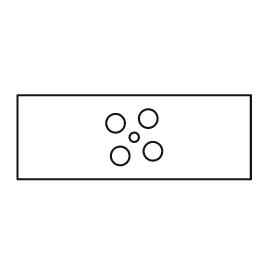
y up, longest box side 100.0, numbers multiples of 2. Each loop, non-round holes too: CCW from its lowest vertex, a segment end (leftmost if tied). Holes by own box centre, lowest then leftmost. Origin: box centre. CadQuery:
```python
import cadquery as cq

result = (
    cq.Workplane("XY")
    .moveTo(-50.0, -18.0)
    .lineTo(50.0, -18.0)
    .lineTo(50.0, 18.0)
    .lineTo(-50.0, 18.0)
    .close()
    .moveTo(-6.0, -8.0)
    .circle(4.0)
    .moveTo(8.0, -6.0)
    .circle(4.0)
    .moveTo(0.0, 0.0)
    .circle(2.0)
    .moveTo(-8.0, 6.0)
    .circle(4.0)
    .moveTo(6.0, 8.0)
    .circle(4.0)
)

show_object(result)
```